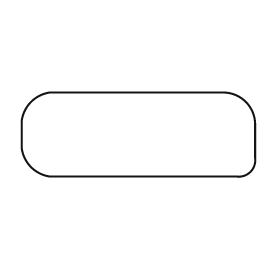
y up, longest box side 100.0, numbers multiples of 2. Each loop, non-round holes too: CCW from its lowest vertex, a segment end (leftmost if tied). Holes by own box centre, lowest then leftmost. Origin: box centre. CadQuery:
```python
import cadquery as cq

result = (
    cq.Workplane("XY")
    .moveTo(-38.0, -18.0)
    .lineTo(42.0, -18.0)
    .threePointArc((48.0, -16.0), (50.0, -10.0))
    .lineTo(50.0, 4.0)
    .threePointArc((46.0, 14.0), (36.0, 18.0))
    .lineTo(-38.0, 18.0)
    .threePointArc((-46.0, 14.0), (-50.0, 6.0))
    .lineTo(-50.0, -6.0)
    .threePointArc((-46.0, -14.0), (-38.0, -18.0))
    .close()
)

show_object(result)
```